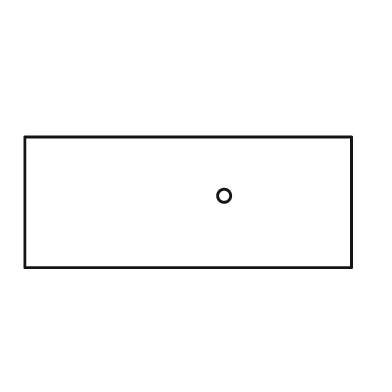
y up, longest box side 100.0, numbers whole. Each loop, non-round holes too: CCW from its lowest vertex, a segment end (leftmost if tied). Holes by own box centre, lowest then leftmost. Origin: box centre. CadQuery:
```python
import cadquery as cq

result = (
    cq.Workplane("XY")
    .moveTo(-50.0, -20.0)
    .lineTo(50.0, -20.0)
    .lineTo(50.0, 20.0)
    .lineTo(-50.0, 20.0)
    .close()
    .moveTo(11.0, 2.0)
    .circle(2.0)
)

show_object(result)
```